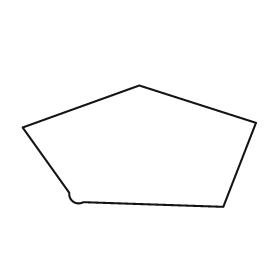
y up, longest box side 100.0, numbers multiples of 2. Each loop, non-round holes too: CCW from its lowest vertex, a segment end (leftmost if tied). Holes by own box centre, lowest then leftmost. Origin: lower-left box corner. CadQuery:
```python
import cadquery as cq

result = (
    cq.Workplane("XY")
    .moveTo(86.0, 0.0)
    .lineTo(100.0, 36.0)
    .lineTo(50.0, 52.0)
    .lineTo(0.0, 34.0)
    .lineTo(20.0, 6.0)
    .threePointArc((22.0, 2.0), (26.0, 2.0))
    .close()
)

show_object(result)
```